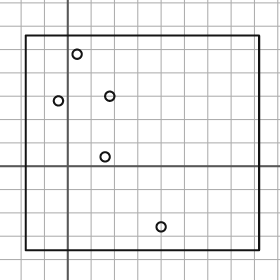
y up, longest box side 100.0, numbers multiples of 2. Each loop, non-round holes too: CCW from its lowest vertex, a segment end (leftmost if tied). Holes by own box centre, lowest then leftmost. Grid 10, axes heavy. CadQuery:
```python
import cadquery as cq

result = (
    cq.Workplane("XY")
    .moveTo(-18.0, -36.0)
    .lineTo(82.0, -36.0)
    .lineTo(82.0, 56.0)
    .lineTo(-18.0, 56.0)
    .close()
    .moveTo(40.0, -26.0)
    .circle(2.0)
    .moveTo(16.0, 4.0)
    .circle(2.0)
    .moveTo(-4.0, 28.0)
    .circle(2.0)
    .moveTo(18.0, 30.0)
    .circle(2.0)
    .moveTo(4.0, 48.0)
    .circle(2.0)
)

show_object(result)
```